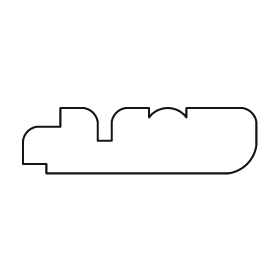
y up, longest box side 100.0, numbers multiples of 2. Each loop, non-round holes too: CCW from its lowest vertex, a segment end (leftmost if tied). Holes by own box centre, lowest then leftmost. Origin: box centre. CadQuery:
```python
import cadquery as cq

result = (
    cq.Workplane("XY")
    .moveTo(-40.0, -14.0)
    .lineTo(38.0, -14.0)
    .threePointArc((46.0, -10.0), (50.0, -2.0))
    .lineTo(50.0, 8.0)
    .threePointArc((48.0, 12.0), (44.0, 14.0))
    .lineTo(20.0, 14.0)
    .lineTo(20.0, 10.0)
    .threePointArc((12.0, 14.0), (4.0, 10.0))
    .lineTo(4.0, 14.0)
    .lineTo(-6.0, 14.0)
    .threePointArc((-10.0, 12.0), (-12.0, 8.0))
    .lineTo(-12.0, 0.0)
    .lineTo(-18.0, 0.0)
    .lineTo(-18.0, 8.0)
    .threePointArc((-20.0, 12.0), (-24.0, 14.0))
    .lineTo(-34.0, 14.0)
    .lineTo(-34.0, 6.0)
    .lineTo(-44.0, 6.0)
    .threePointArc((-48.0, 4.0), (-50.0, 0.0))
    .lineTo(-50.0, -10.0)
    .lineTo(-40.0, -10.0)
    .close()
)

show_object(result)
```